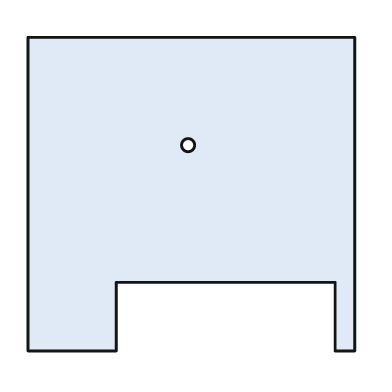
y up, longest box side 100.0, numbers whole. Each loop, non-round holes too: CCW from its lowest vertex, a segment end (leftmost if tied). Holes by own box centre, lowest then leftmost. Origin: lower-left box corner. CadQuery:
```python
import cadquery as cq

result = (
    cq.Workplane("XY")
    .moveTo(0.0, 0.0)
    .lineTo(27.0, 0.0)
    .lineTo(27.0, 21.0)
    .lineTo(94.0, 21.0)
    .lineTo(94.0, 0.0)
    .lineTo(100.0, 0.0)
    .lineTo(100.0, 96.0)
    .lineTo(0.0, 96.0)
    .close()
    .moveTo(49.0, 63.0)
    .circle(2.0)
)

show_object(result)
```